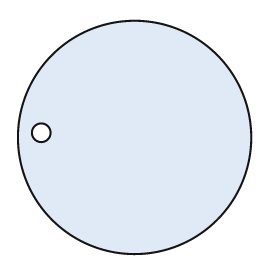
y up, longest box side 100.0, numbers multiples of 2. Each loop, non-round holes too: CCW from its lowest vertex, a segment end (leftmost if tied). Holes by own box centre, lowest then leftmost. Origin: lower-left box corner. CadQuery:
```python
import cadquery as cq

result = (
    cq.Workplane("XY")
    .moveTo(50.0, 50.0)
    .circle(50.0)
    .moveTo(10.0, 52.0)
    .circle(4.0)
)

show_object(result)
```